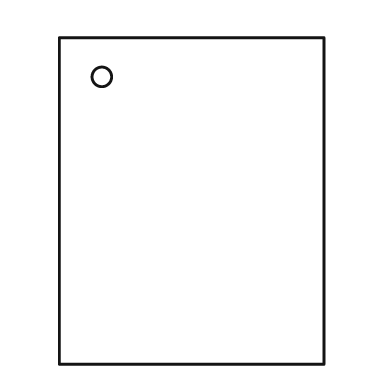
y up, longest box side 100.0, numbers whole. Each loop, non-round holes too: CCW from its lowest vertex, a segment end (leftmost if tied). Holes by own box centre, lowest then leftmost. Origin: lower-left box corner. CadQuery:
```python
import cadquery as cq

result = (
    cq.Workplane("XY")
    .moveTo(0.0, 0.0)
    .lineTo(81.0, 0.0)
    .lineTo(81.0, 100.0)
    .lineTo(0.0, 100.0)
    .close()
    .moveTo(13.0, 88.0)
    .circle(3.0)
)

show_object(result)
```